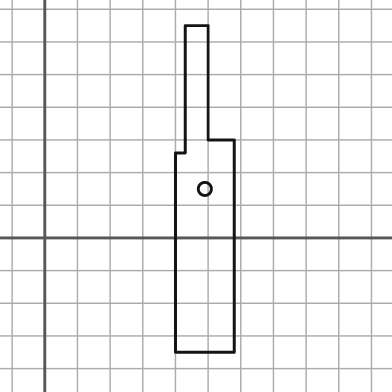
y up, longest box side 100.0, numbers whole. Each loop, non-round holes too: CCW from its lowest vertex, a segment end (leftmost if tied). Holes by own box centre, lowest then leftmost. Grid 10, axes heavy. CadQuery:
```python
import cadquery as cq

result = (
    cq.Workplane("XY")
    .moveTo(40.0, -35.0)
    .lineTo(58.0, -35.0)
    .lineTo(58.0, 30.0)
    .lineTo(50.0, 30.0)
    .lineTo(50.0, 65.0)
    .lineTo(43.0, 65.0)
    .lineTo(43.0, 26.0)
    .lineTo(40.0, 26.0)
    .close()
    .moveTo(49.0, 15.0)
    .circle(2.0)
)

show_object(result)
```